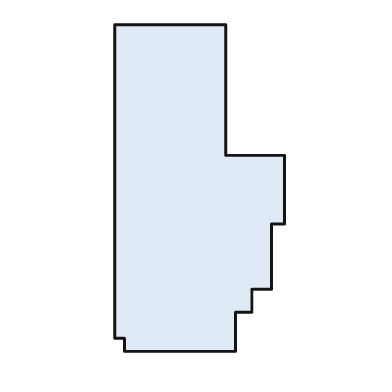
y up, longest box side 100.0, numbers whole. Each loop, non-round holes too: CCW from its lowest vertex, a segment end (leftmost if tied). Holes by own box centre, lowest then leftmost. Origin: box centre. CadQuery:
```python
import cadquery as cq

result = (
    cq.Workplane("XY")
    .moveTo(-23.0, -50.0)
    .lineTo(11.0, -50.0)
    .lineTo(11.0, -38.0)
    .lineTo(16.0, -38.0)
    .lineTo(16.0, -31.0)
    .lineTo(22.0, -31.0)
    .lineTo(22.0, -11.0)
    .lineTo(26.0, -11.0)
    .lineTo(26.0, 10.0)
    .lineTo(8.0, 10.0)
    .lineTo(8.0, 50.0)
    .lineTo(-26.0, 50.0)
    .lineTo(-26.0, -46.0)
    .lineTo(-23.0, -46.0)
    .close()
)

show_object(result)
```